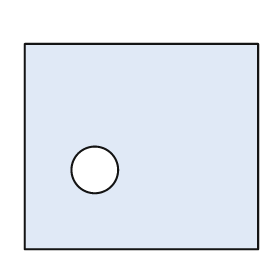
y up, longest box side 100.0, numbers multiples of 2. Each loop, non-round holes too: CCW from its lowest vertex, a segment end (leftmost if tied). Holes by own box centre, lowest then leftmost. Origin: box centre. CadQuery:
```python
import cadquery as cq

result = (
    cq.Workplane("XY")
    .moveTo(-50.0, -44.0)
    .lineTo(50.0, -44.0)
    .lineTo(50.0, 44.0)
    .lineTo(-50.0, 44.0)
    .close()
    .moveTo(-20.0, -10.0)
    .circle(10.0)
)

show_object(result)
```